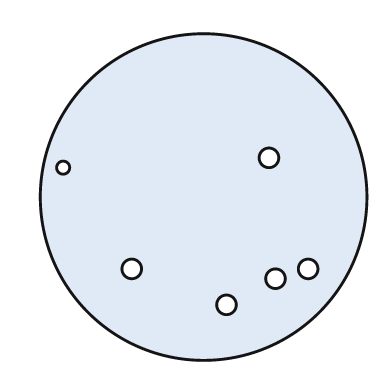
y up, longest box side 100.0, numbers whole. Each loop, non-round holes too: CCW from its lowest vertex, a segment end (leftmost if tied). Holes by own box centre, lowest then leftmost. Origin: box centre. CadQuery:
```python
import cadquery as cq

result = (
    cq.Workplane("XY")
    .moveTo(0.0, 0.0)
    .circle(50.0)
    .moveTo(7.0, -33.0)
    .circle(3.0)
    .moveTo(22.0, -25.0)
    .circle(3.0)
    .moveTo(-22.0, -22.0)
    .circle(3.0)
    .moveTo(32.0, -22.0)
    .circle(3.0)
    .moveTo(-43.0, 9.0)
    .circle(2.0)
    .moveTo(20.0, 12.0)
    .circle(3.0)
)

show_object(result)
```